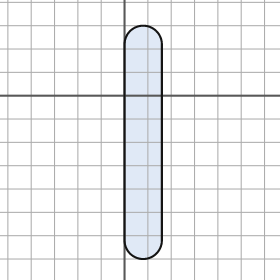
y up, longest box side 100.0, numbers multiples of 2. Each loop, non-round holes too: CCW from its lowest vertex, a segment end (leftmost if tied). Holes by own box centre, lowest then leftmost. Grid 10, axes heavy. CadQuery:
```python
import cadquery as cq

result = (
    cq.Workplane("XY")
    .moveTo(0.0, -62.0)
    .threePointArc((8.0, -70.0), (16.0, -62.0))
    .lineTo(16.0, 22.0)
    .threePointArc((8.0, 30.0), (0.0, 22.0))
    .close()
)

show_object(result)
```